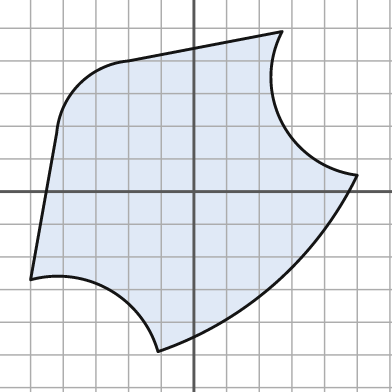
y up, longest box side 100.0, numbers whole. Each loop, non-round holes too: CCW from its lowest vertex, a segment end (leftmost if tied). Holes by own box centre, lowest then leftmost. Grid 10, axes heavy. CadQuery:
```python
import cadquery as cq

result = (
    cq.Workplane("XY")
    .moveTo(-11.0, -49.0)
    .threePointArc((25.0, -28.0), (50.0, 5.0))
    .threePointArc((27.0, 21.0), (27.0, 49.0))
    .lineTo(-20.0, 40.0)
    .threePointArc((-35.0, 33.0), (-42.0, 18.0))
    .lineTo(-50.0, -27.0)
    .threePointArc((-26.0, -30.0), (-11.0, -49.0))
    .close()
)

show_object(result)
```